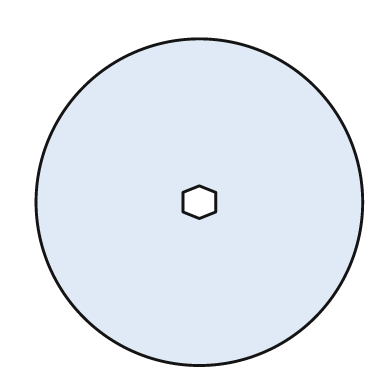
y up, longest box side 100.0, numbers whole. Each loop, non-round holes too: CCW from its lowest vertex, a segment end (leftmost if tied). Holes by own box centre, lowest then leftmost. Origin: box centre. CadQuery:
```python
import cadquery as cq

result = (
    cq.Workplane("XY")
    .moveTo(0.0, 0.0)
    .circle(50.0)
    .moveTo(0.0, -5.0)
    .lineTo(5.0, -3.0)
    .lineTo(5.0, 3.0)
    .lineTo(0.0, 5.0)
    .lineTo(-5.0, 3.0)
    .lineTo(-5.0, -3.0)
    .close()
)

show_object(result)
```